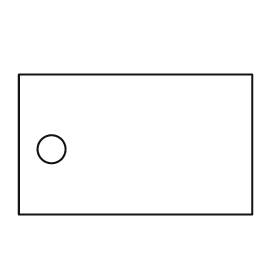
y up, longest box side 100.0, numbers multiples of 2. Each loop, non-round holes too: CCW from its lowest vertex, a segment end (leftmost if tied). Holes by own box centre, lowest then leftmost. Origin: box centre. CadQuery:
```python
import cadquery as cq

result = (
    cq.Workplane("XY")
    .moveTo(-50.0, -30.0)
    .lineTo(50.0, -30.0)
    .lineTo(50.0, 30.0)
    .lineTo(-50.0, 30.0)
    .close()
    .moveTo(-36.0, -2.0)
    .circle(6.0)
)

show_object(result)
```